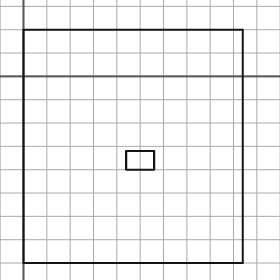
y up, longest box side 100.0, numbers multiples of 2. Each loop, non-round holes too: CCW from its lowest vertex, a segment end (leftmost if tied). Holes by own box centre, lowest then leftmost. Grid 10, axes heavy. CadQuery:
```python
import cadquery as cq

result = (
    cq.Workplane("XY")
    .moveTo(0.0, -80.0)
    .lineTo(94.0, -80.0)
    .lineTo(94.0, 20.0)
    .lineTo(0.0, 20.0)
    .close()
    .moveTo(44.0, -40.0)
    .lineTo(56.0, -40.0)
    .lineTo(56.0, -32.0)
    .lineTo(44.0, -32.0)
    .close()
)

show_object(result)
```